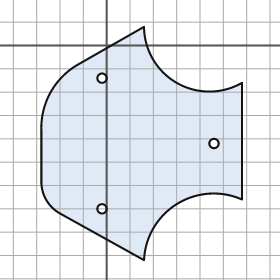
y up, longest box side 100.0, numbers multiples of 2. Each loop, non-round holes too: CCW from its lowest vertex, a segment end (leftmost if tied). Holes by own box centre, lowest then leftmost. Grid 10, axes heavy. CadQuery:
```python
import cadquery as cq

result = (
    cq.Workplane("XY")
    .moveTo(16.0, -92.0)
    .threePointArc((30.0, -68.0), (58.0, -66.0))
    .lineTo(58.0, -16.0)
    .threePointArc((30.0, -16.0), (16.0, 8.0))
    .lineTo(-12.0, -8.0)
    .threePointArc((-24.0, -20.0), (-28.0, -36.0))
    .lineTo(-28.0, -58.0)
    .threePointArc((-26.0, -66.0), (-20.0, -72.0))
    .close()
    .moveTo(-2.0, -70.0)
    .circle(2.0)
    .moveTo(46.0, -42.0)
    .circle(2.0)
    .moveTo(-2.0, -14.0)
    .circle(2.0)
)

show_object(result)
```